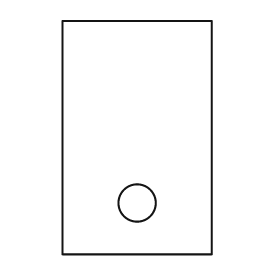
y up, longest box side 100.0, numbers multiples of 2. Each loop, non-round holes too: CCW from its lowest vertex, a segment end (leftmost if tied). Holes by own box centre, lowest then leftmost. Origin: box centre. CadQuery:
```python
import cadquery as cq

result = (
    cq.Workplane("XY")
    .moveTo(-32.0, -50.0)
    .lineTo(32.0, -50.0)
    .lineTo(32.0, 50.0)
    .lineTo(-32.0, 50.0)
    .close()
    .moveTo(0.0, -28.0)
    .circle(8.0)
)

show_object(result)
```